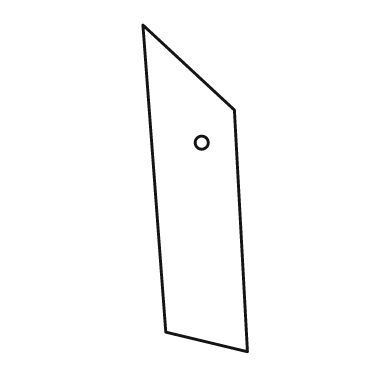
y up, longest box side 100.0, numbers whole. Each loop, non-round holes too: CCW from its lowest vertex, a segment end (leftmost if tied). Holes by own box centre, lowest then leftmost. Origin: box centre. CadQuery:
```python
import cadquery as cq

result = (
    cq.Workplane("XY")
    .moveTo(16.0, -50.0)
    .lineTo(12.0, 24.0)
    .lineTo(-16.0, 50.0)
    .lineTo(-9.0, -44.0)
    .close()
    .moveTo(2.0, 14.0)
    .circle(2.0)
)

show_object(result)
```